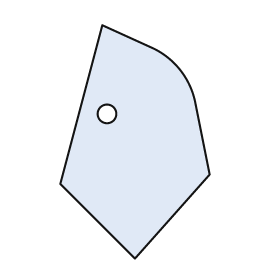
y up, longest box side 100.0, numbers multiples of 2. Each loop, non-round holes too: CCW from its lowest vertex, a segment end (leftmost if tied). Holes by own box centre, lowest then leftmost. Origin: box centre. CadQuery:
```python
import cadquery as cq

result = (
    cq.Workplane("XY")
    .moveTo(0.0, -50.0)
    .lineTo(32.0, -14.0)
    .lineTo(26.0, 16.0)
    .threePointArc((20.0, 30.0), (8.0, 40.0))
    .lineTo(-14.0, 50.0)
    .lineTo(-32.0, -18.0)
    .close()
    .moveTo(-12.0, 12.0)
    .circle(4.0)
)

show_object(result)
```